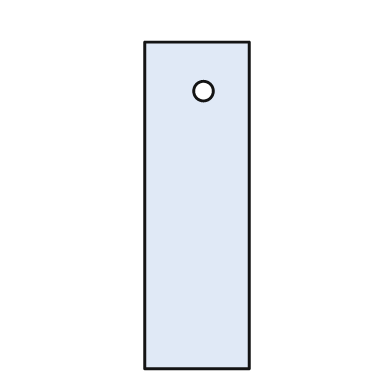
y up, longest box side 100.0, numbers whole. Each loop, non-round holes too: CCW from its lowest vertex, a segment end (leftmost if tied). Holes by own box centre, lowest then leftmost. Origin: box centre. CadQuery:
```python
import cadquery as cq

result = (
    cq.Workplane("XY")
    .moveTo(-16.0, -50.0)
    .lineTo(16.0, -50.0)
    .lineTo(16.0, 50.0)
    .lineTo(-16.0, 50.0)
    .close()
    .moveTo(2.0, 35.0)
    .circle(3.0)
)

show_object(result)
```